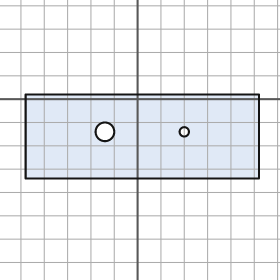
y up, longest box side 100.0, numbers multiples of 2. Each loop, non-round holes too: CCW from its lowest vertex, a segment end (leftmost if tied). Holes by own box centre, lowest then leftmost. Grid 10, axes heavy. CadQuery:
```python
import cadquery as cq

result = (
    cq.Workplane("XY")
    .moveTo(-48.0, -34.0)
    .lineTo(52.0, -34.0)
    .lineTo(52.0, 2.0)
    .lineTo(-48.0, 2.0)
    .close()
    .moveTo(-14.0, -14.0)
    .circle(4.0)
    .moveTo(20.0, -14.0)
    .circle(2.0)
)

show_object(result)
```